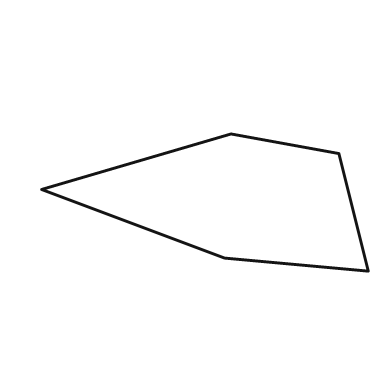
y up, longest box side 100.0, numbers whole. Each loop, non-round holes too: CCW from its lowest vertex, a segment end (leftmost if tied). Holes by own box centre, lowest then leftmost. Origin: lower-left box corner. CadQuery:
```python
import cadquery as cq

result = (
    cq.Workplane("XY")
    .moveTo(100.0, 0.0)
    .lineTo(91.0, 36.0)
    .lineTo(58.0, 42.0)
    .lineTo(0.0, 25.0)
    .lineTo(56.0, 4.0)
    .close()
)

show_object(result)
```